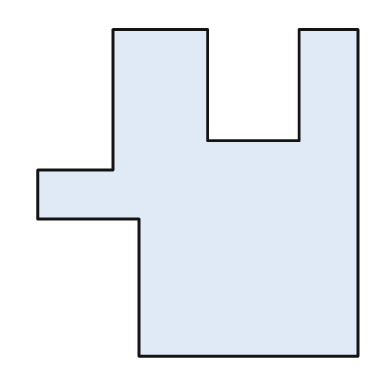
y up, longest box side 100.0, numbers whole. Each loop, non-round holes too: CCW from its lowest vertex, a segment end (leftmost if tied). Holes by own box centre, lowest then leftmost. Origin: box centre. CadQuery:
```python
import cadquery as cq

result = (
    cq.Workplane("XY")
    .moveTo(-18.0, -50.0)
    .lineTo(49.0, -50.0)
    .lineTo(49.0, 50.0)
    .lineTo(31.0, 50.0)
    .lineTo(31.0, 16.0)
    .lineTo(3.0, 16.0)
    .lineTo(3.0, 50.0)
    .lineTo(-26.0, 50.0)
    .lineTo(-26.0, 7.0)
    .lineTo(-49.0, 7.0)
    .lineTo(-49.0, -8.0)
    .lineTo(-18.0, -8.0)
    .close()
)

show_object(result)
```